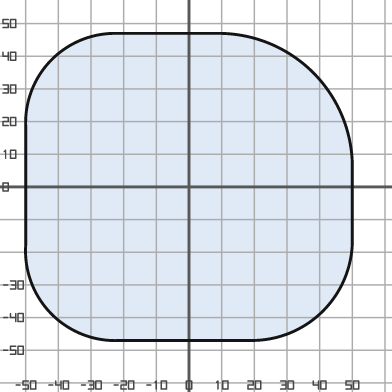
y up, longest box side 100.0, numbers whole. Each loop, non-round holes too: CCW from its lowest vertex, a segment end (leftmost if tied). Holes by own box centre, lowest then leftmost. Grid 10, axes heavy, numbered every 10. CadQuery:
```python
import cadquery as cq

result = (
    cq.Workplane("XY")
    .moveTo(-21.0, -47.0)
    .lineTo(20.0, -47.0)
    .threePointArc((41.0, -38.0), (50.0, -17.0))
    .lineTo(50.0, 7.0)
    .threePointArc((38.0, 35.0), (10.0, 47.0))
    .lineTo(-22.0, 47.0)
    .threePointArc((-42.0, 39.0), (-50.0, 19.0))
    .lineTo(-50.0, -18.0)
    .threePointArc((-42.0, -39.0), (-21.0, -47.0))
    .close()
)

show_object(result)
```